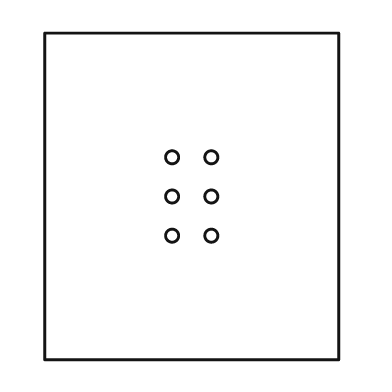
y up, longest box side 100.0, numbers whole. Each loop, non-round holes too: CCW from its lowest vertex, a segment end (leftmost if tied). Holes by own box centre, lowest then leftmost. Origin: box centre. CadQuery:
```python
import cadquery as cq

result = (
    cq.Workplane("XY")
    .moveTo(-45.0, -50.0)
    .lineTo(45.0, -50.0)
    .lineTo(45.0, 50.0)
    .lineTo(-45.0, 50.0)
    .close()
    .moveTo(-6.0, -12.0)
    .circle(2.0)
    .moveTo(6.0, -12.0)
    .circle(2.0)
    .moveTo(-6.0, 0.0)
    .circle(2.0)
    .moveTo(6.0, 0.0)
    .circle(2.0)
    .moveTo(-6.0, 12.0)
    .circle(2.0)
    .moveTo(6.0, 12.0)
    .circle(2.0)
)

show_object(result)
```